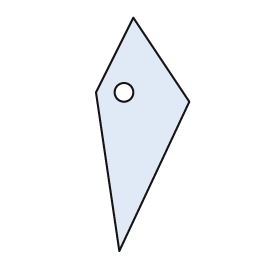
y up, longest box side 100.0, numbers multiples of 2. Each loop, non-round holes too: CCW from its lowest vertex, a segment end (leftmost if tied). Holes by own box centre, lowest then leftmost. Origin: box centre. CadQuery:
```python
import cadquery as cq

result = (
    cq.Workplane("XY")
    .moveTo(-10.0, -50.0)
    .lineTo(20.0, 14.0)
    .lineTo(-4.0, 50.0)
    .lineTo(-20.0, 18.0)
    .close()
    .moveTo(-8.0, 18.0)
    .circle(4.0)
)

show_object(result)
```